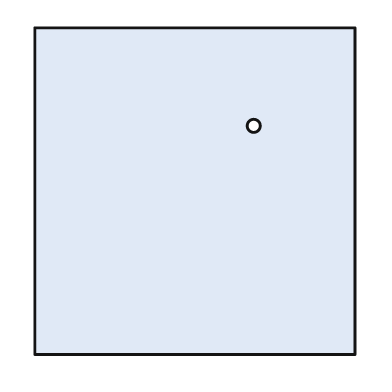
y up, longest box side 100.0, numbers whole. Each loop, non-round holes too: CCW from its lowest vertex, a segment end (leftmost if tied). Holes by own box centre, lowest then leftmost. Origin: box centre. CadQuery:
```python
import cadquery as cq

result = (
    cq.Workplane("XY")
    .moveTo(-49.0, -50.0)
    .lineTo(49.0, -50.0)
    .lineTo(49.0, 50.0)
    .lineTo(-49.0, 50.0)
    .close()
    .moveTo(18.0, 20.0)
    .circle(2.0)
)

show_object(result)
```